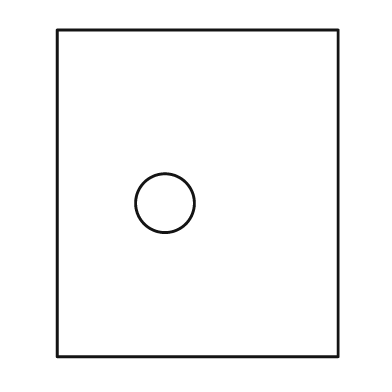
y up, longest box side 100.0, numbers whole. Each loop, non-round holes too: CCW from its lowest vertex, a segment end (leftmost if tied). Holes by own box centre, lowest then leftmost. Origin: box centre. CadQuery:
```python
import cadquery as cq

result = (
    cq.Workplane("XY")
    .moveTo(-43.0, -50.0)
    .lineTo(43.0, -50.0)
    .lineTo(43.0, 50.0)
    .lineTo(-43.0, 50.0)
    .close()
    .moveTo(-10.0, -3.0)
    .circle(9.0)
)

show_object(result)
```